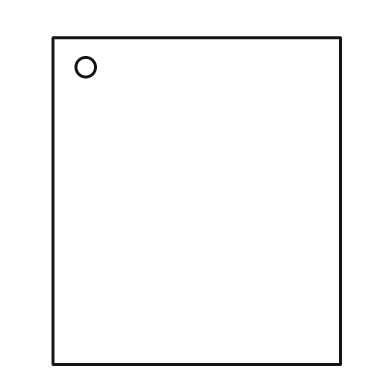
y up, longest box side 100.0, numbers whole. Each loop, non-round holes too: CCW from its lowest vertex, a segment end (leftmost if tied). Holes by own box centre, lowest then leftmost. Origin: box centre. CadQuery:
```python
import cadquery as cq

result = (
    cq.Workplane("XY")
    .moveTo(-44.0, -50.0)
    .lineTo(44.0, -50.0)
    .lineTo(44.0, 50.0)
    .lineTo(-44.0, 50.0)
    .close()
    .moveTo(-34.0, 41.0)
    .circle(3.0)
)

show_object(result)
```